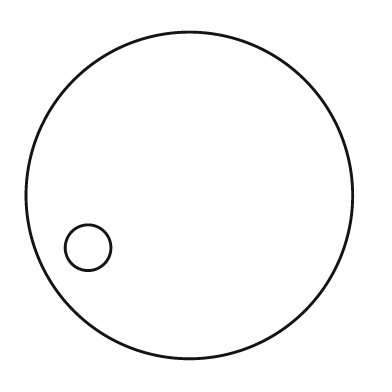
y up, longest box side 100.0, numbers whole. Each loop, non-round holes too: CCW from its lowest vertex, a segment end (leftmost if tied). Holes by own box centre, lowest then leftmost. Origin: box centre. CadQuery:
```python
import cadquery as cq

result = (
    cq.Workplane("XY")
    .moveTo(0.0, 0.0)
    .circle(50.0)
    .moveTo(-31.0, -16.0)
    .circle(7.0)
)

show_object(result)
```